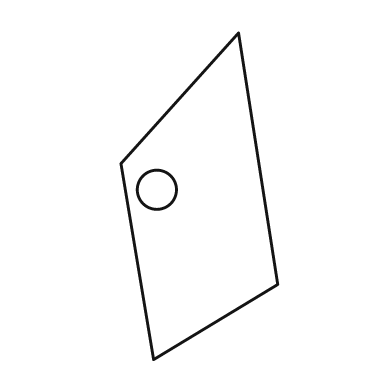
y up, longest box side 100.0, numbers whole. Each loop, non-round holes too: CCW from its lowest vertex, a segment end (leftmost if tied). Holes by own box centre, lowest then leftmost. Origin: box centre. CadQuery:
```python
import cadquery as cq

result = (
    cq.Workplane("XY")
    .moveTo(-14.0, -50.0)
    .lineTo(24.0, -27.0)
    .lineTo(12.0, 50.0)
    .lineTo(-24.0, 10.0)
    .close()
    .moveTo(-13.0, 2.0)
    .circle(6.0)
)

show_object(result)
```